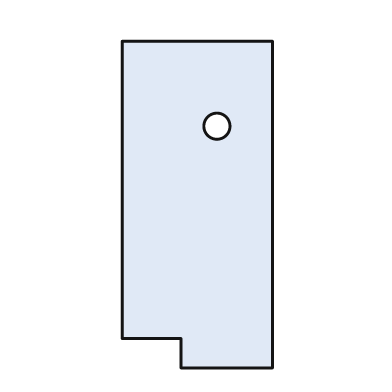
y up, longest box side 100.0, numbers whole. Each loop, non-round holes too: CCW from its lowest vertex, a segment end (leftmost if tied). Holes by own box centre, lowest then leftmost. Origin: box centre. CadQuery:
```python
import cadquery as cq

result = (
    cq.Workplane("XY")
    .moveTo(-5.0, -50.0)
    .lineTo(23.0, -50.0)
    .lineTo(23.0, 50.0)
    .lineTo(-23.0, 50.0)
    .lineTo(-23.0, -41.0)
    .lineTo(-5.0, -41.0)
    .close()
    .moveTo(6.0, 24.0)
    .circle(4.0)
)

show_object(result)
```